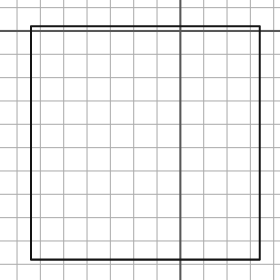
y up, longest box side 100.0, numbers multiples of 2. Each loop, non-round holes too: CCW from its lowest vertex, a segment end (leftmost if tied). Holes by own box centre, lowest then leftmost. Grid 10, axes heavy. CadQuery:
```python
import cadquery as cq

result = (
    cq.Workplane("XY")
    .moveTo(-64.0, -98.0)
    .lineTo(34.0, -98.0)
    .lineTo(34.0, 2.0)
    .lineTo(-64.0, 2.0)
    .close()
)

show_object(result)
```